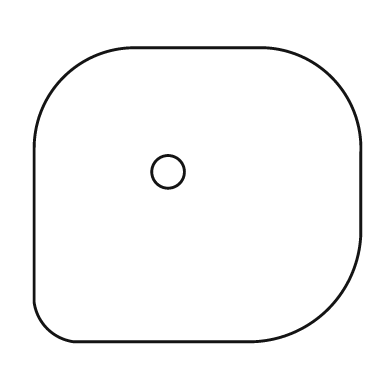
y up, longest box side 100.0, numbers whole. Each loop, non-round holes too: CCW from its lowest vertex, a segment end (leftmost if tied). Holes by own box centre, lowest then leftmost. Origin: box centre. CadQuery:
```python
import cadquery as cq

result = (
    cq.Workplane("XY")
    .moveTo(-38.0, -45.0)
    .lineTo(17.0, -45.0)
    .threePointArc((40.0, -35.0), (50.0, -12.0))
    .lineTo(50.0, 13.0)
    .threePointArc((41.0, 36.0), (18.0, 45.0))
    .lineTo(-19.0, 45.0)
    .threePointArc((-41.0, 36.0), (-50.0, 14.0))
    .lineTo(-50.0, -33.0)
    .threePointArc((-46.0, -41.0), (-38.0, -45.0))
    .close()
    .moveTo(-9.0, 7.0)
    .circle(5.0)
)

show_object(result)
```